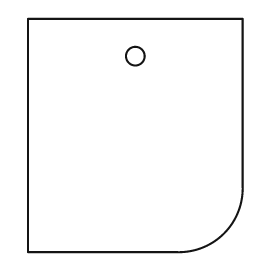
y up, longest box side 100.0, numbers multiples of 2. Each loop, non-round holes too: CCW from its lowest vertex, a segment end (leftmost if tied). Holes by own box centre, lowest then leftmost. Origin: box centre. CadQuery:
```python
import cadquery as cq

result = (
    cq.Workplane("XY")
    .moveTo(-46.0, -50.0)
    .lineTo(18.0, -50.0)
    .threePointArc((38.0, -42.0), (46.0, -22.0))
    .lineTo(46.0, 50.0)
    .lineTo(-46.0, 50.0)
    .close()
    .moveTo(0.0, 34.0)
    .circle(4.0)
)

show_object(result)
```